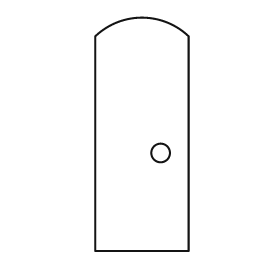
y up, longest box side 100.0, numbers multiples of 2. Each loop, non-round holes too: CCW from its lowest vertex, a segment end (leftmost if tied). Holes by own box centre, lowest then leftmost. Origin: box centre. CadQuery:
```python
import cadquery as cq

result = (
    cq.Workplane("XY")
    .moveTo(-20.0, -50.0)
    .lineTo(20.0, -50.0)
    .lineTo(20.0, 42.0)
    .threePointArc((0.0, 50.0), (-20.0, 42.0))
    .close()
    .moveTo(8.0, -8.0)
    .circle(4.0)
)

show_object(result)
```